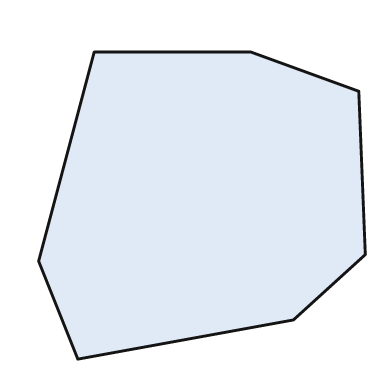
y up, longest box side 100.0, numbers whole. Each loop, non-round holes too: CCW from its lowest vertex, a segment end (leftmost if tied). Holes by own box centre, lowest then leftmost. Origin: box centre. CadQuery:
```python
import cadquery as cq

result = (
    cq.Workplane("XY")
    .moveTo(-38.0, -47.0)
    .lineTo(28.0, -35.0)
    .lineTo(50.0, -15.0)
    .lineTo(48.0, 35.0)
    .lineTo(15.0, 47.0)
    .lineTo(-33.0, 47.0)
    .lineTo(-50.0, -17.0)
    .close()
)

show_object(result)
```